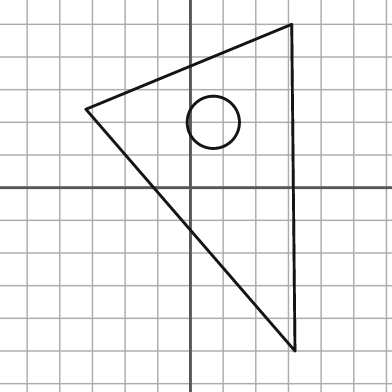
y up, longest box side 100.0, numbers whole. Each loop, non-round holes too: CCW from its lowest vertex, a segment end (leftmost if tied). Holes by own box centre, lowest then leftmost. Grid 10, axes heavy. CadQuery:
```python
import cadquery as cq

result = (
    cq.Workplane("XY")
    .moveTo(32.0, -50.0)
    .lineTo(31.0, 50.0)
    .lineTo(-32.0, 24.0)
    .close()
    .moveTo(7.0, 20.0)
    .circle(8.0)
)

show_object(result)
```